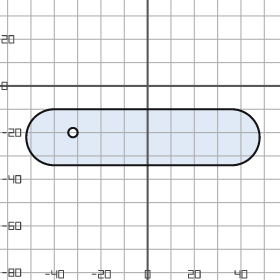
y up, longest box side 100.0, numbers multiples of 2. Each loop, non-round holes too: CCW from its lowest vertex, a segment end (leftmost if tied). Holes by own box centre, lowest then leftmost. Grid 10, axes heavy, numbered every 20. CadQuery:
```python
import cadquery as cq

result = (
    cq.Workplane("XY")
    .moveTo(-40.0, -34.0)
    .lineTo(36.0, -34.0)
    .threePointArc((48.0, -22.0), (36.0, -10.0))
    .lineTo(-40.0, -10.0)
    .threePointArc((-52.0, -22.0), (-40.0, -34.0))
    .close()
    .moveTo(-32.0, -20.0)
    .circle(2.0)
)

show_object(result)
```